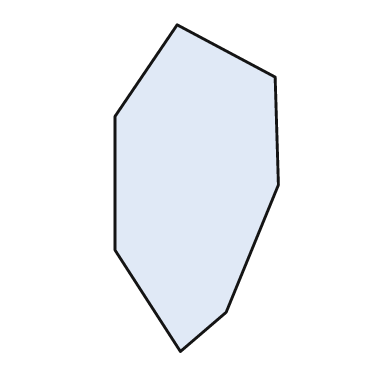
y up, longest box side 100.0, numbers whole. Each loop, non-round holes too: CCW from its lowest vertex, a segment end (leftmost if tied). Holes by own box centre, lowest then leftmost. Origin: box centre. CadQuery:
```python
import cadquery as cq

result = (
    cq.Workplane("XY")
    .moveTo(-5.0, -50.0)
    .lineTo(9.0, -38.0)
    .lineTo(25.0, 1.0)
    .lineTo(24.0, 34.0)
    .lineTo(-6.0, 50.0)
    .lineTo(-25.0, 22.0)
    .lineTo(-25.0, -19.0)
    .close()
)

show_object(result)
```